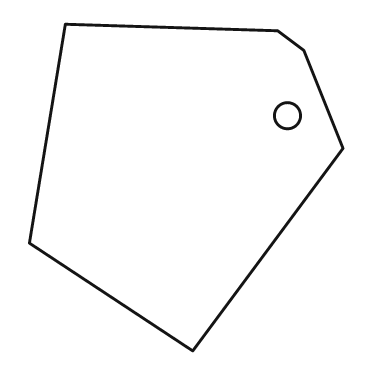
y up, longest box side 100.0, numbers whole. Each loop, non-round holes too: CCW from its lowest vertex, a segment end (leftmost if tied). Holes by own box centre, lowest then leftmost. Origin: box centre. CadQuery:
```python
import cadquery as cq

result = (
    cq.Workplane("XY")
    .moveTo(2.0, -50.0)
    .lineTo(48.0, 12.0)
    .lineTo(36.0, 42.0)
    .lineTo(28.0, 48.0)
    .lineTo(-37.0, 50.0)
    .lineTo(-48.0, -17.0)
    .close()
    .moveTo(31.0, 22.0)
    .circle(4.0)
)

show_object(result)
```